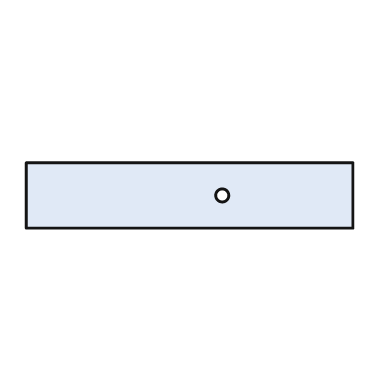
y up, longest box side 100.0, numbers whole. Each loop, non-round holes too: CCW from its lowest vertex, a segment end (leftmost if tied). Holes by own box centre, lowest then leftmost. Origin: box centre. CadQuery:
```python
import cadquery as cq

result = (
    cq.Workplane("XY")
    .moveTo(-50.0, -10.0)
    .lineTo(50.0, -10.0)
    .lineTo(50.0, 10.0)
    .lineTo(-50.0, 10.0)
    .close()
    .moveTo(10.0, 0.0)
    .circle(2.0)
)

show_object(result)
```